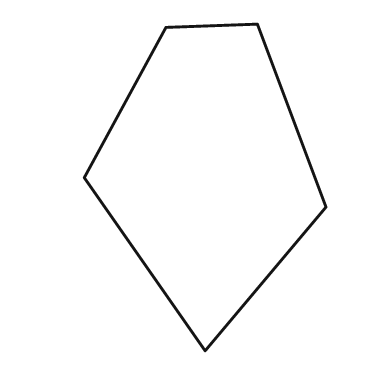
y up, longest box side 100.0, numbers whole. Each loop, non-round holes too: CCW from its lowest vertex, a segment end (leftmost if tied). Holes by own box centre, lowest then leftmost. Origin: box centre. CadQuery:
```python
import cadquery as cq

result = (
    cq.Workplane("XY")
    .moveTo(0.0, -50.0)
    .lineTo(37.0, -6.0)
    .lineTo(16.0, 50.0)
    .lineTo(-12.0, 49.0)
    .lineTo(-37.0, 3.0)
    .close()
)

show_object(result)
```